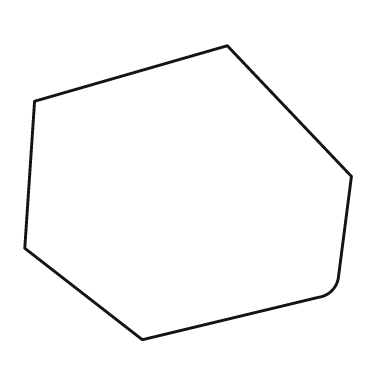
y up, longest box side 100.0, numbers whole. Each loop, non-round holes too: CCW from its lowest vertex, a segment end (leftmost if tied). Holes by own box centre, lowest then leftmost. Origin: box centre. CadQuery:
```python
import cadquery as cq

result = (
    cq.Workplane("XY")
    .moveTo(-14.0, -45.0)
    .lineTo(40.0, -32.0)
    .threePointArc((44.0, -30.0), (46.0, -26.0))
    .lineTo(50.0, 5.0)
    .lineTo(12.0, 45.0)
    .lineTo(-47.0, 28.0)
    .lineTo(-50.0, -17.0)
    .close()
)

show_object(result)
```